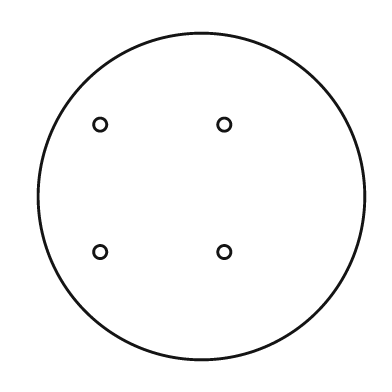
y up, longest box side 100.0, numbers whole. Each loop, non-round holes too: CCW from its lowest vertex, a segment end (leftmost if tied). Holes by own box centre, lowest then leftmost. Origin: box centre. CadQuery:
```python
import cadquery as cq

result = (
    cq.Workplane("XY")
    .moveTo(0.0, 0.0)
    .circle(50.0)
    .moveTo(-31.0, -17.0)
    .circle(2.0)
    .moveTo(7.0, -17.0)
    .circle(2.0)
    .moveTo(-31.0, 22.0)
    .circle(2.0)
    .moveTo(7.0, 22.0)
    .circle(2.0)
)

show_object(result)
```